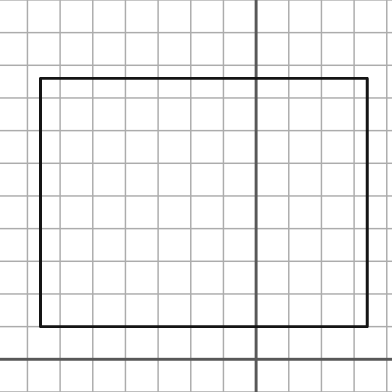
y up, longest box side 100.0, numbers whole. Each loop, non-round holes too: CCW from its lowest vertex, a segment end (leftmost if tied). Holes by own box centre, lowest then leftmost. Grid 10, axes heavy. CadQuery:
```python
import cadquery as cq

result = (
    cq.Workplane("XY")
    .moveTo(-66.0, 10.0)
    .lineTo(34.0, 10.0)
    .lineTo(34.0, 86.0)
    .lineTo(-66.0, 86.0)
    .close()
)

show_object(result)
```